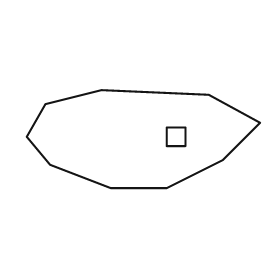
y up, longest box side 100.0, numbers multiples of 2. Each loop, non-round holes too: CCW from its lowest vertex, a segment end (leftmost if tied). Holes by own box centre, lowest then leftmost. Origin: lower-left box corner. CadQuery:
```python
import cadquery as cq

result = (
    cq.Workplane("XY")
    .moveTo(36.0, 0.0)
    .lineTo(60.0, 0.0)
    .lineTo(84.0, 12.0)
    .lineTo(100.0, 28.0)
    .lineTo(78.0, 40.0)
    .lineTo(32.0, 42.0)
    .lineTo(8.0, 36.0)
    .lineTo(0.0, 22.0)
    .lineTo(10.0, 10.0)
    .close()
    .moveTo(60.0, 18.0)
    .lineTo(68.0, 18.0)
    .lineTo(68.0, 26.0)
    .lineTo(60.0, 26.0)
    .close()
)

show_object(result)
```